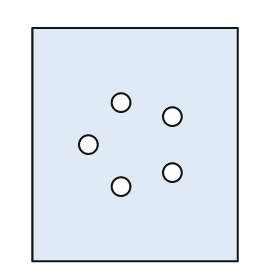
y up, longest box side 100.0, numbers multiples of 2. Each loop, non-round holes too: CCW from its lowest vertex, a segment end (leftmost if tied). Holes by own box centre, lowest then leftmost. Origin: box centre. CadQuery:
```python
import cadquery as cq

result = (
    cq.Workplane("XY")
    .moveTo(-44.0, -50.0)
    .lineTo(44.0, -50.0)
    .lineTo(44.0, 50.0)
    .lineTo(-44.0, 50.0)
    .close()
    .moveTo(-6.0, -18.0)
    .circle(4.0)
    .moveTo(16.0, -12.0)
    .circle(4.0)
    .moveTo(-20.0, 0.0)
    .circle(4.0)
    .moveTo(16.0, 12.0)
    .circle(4.0)
    .moveTo(-6.0, 18.0)
    .circle(4.0)
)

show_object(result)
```